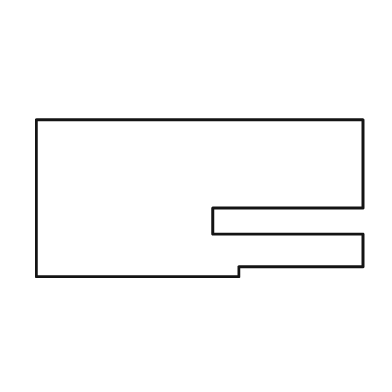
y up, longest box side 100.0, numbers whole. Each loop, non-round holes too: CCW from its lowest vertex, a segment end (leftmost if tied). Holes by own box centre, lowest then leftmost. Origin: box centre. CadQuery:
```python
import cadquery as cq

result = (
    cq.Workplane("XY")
    .moveTo(-50.0, -24.0)
    .lineTo(12.0, -24.0)
    .lineTo(12.0, -21.0)
    .lineTo(50.0, -21.0)
    .lineTo(50.0, -11.0)
    .lineTo(4.0, -11.0)
    .lineTo(4.0, -3.0)
    .lineTo(50.0, -3.0)
    .lineTo(50.0, 24.0)
    .lineTo(-50.0, 24.0)
    .close()
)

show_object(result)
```